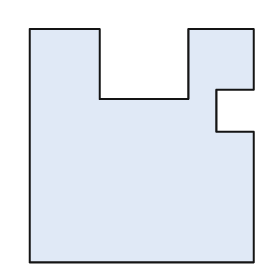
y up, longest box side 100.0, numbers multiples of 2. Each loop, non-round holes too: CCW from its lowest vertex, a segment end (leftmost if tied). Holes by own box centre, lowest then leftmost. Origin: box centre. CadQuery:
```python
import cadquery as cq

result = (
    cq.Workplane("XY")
    .moveTo(-48.0, -50.0)
    .lineTo(48.0, -50.0)
    .lineTo(48.0, 6.0)
    .lineTo(32.0, 6.0)
    .lineTo(32.0, 24.0)
    .lineTo(48.0, 24.0)
    .lineTo(48.0, 50.0)
    .lineTo(20.0, 50.0)
    .lineTo(20.0, 20.0)
    .lineTo(-18.0, 20.0)
    .lineTo(-18.0, 50.0)
    .lineTo(-48.0, 50.0)
    .close()
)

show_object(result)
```